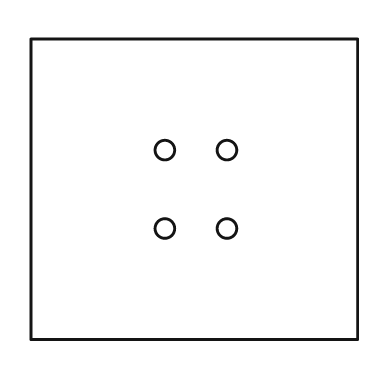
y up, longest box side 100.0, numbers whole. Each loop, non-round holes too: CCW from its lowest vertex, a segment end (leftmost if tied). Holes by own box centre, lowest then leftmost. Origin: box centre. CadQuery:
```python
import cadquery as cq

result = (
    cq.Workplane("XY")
    .moveTo(-50.0, -46.0)
    .lineTo(50.0, -46.0)
    .lineTo(50.0, 46.0)
    .lineTo(-50.0, 46.0)
    .close()
    .moveTo(-9.0, -12.0)
    .circle(3.0)
    .moveTo(10.0, -12.0)
    .circle(3.0)
    .moveTo(-9.0, 12.0)
    .circle(3.0)
    .moveTo(10.0, 12.0)
    .circle(3.0)
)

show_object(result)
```